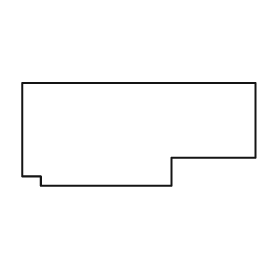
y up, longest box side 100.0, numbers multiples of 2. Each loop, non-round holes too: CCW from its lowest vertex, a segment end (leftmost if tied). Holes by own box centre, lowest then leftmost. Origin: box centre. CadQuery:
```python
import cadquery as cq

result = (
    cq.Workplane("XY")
    .moveTo(-42.0, -22.0)
    .lineTo(14.0, -22.0)
    .lineTo(14.0, -10.0)
    .lineTo(50.0, -10.0)
    .lineTo(50.0, 22.0)
    .lineTo(-50.0, 22.0)
    .lineTo(-50.0, -18.0)
    .lineTo(-42.0, -18.0)
    .close()
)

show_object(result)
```